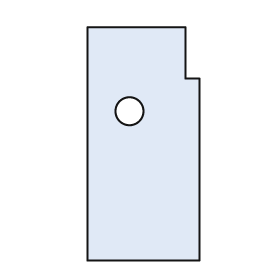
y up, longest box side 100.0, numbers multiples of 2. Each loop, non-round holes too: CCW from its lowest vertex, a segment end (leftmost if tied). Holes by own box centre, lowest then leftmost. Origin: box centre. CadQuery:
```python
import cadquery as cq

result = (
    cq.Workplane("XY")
    .moveTo(-24.0, -50.0)
    .lineTo(24.0, -50.0)
    .lineTo(24.0, 28.0)
    .lineTo(18.0, 28.0)
    .lineTo(18.0, 50.0)
    .lineTo(-24.0, 50.0)
    .close()
    .moveTo(-6.0, 14.0)
    .circle(6.0)
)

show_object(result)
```